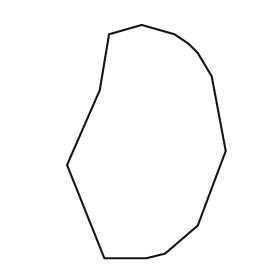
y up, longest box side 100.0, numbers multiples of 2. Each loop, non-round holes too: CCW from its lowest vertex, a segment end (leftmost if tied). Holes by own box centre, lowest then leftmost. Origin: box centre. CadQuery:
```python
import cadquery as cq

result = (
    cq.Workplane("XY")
    .moveTo(-18.0, -50.0)
    .lineTo(0.0, -50.0)
    .lineTo(8.0, -48.0)
    .lineTo(22.0, -36.0)
    .lineTo(34.0, -4.0)
    .lineTo(28.0, 28.0)
    .lineTo(22.0, 38.0)
    .lineTo(18.0, 42.0)
    .lineTo(12.0, 46.0)
    .lineTo(-2.0, 50.0)
    .lineTo(-16.0, 46.0)
    .lineTo(-20.0, 22.0)
    .lineTo(-34.0, -10.0)
    .close()
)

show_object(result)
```